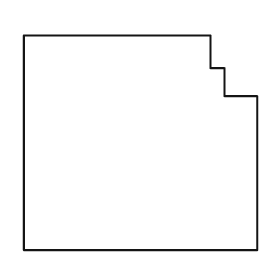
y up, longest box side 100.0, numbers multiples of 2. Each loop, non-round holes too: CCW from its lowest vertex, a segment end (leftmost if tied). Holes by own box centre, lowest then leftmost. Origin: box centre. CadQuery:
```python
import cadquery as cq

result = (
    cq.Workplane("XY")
    .moveTo(-50.0, -46.0)
    .lineTo(50.0, -46.0)
    .lineTo(50.0, 20.0)
    .lineTo(36.0, 20.0)
    .lineTo(36.0, 32.0)
    .lineTo(30.0, 32.0)
    .lineTo(30.0, 46.0)
    .lineTo(-50.0, 46.0)
    .close()
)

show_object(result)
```